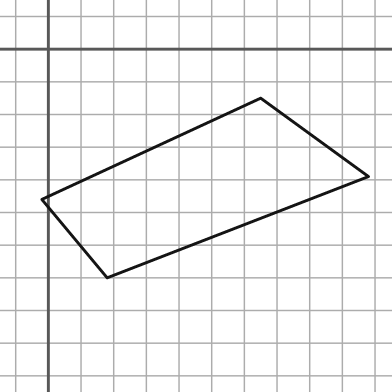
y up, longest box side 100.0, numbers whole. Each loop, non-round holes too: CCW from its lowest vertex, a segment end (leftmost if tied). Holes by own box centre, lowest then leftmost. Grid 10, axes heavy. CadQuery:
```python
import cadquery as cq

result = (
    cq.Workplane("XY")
    .moveTo(18.0, -70.0)
    .lineTo(98.0, -39.0)
    .lineTo(65.0, -15.0)
    .lineTo(-2.0, -46.0)
    .close()
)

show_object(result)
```